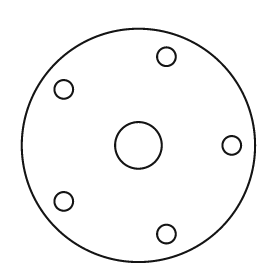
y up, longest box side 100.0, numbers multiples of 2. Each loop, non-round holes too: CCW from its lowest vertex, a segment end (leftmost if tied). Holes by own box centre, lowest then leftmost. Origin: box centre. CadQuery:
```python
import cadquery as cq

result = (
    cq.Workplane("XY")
    .moveTo(0.0, 0.0)
    .circle(50.0)
    .moveTo(12.0, -38.0)
    .circle(4.0)
    .moveTo(-32.0, -24.0)
    .circle(4.0)
    .moveTo(0.0, 0.0)
    .circle(10.0)
    .moveTo(40.0, 0.0)
    .circle(4.0)
    .moveTo(-32.0, 24.0)
    .circle(4.0)
    .moveTo(12.0, 38.0)
    .circle(4.0)
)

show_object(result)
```